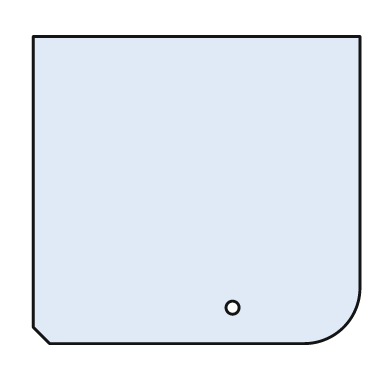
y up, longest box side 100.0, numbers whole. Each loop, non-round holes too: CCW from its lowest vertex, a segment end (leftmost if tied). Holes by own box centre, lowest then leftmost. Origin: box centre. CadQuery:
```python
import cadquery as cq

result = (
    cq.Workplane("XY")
    .moveTo(-45.0, -47.0)
    .lineTo(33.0, -47.0)
    .threePointArc((45.0, -42.0), (50.0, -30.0))
    .lineTo(50.0, 47.0)
    .lineTo(-50.0, 47.0)
    .lineTo(-50.0, -42.0)
    .close()
    .moveTo(11.0, -36.0)
    .circle(2.0)
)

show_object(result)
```